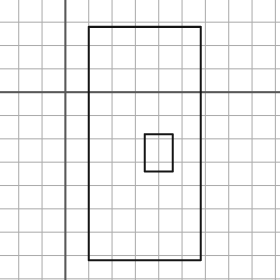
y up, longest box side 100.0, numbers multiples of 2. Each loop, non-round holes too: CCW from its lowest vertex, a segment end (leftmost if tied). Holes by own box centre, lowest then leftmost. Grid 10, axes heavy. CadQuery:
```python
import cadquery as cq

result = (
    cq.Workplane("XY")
    .moveTo(10.0, -72.0)
    .lineTo(58.0, -72.0)
    .lineTo(58.0, 28.0)
    .lineTo(10.0, 28.0)
    .close()
    .moveTo(34.0, -34.0)
    .lineTo(46.0, -34.0)
    .lineTo(46.0, -18.0)
    .lineTo(34.0, -18.0)
    .close()
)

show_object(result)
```